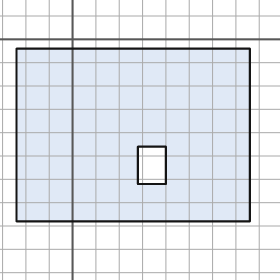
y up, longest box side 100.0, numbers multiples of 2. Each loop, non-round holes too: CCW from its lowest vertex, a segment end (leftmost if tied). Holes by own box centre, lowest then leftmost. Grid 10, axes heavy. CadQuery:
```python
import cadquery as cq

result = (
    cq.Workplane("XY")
    .moveTo(-24.0, -78.0)
    .lineTo(76.0, -78.0)
    .lineTo(76.0, -4.0)
    .lineTo(-24.0, -4.0)
    .close()
    .moveTo(28.0, -62.0)
    .lineTo(40.0, -62.0)
    .lineTo(40.0, -46.0)
    .lineTo(28.0, -46.0)
    .close()
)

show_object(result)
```